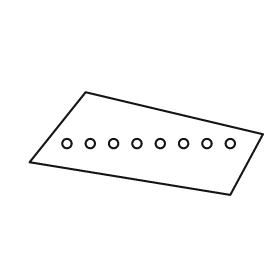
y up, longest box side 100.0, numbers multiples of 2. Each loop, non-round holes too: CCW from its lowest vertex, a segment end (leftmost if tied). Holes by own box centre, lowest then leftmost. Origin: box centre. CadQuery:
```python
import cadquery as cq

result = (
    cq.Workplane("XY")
    .moveTo(36.0, -22.0)
    .lineTo(50.0, 4.0)
    .lineTo(-26.0, 22.0)
    .lineTo(-50.0, -8.0)
    .close()
    .moveTo(-34.0, 0.0)
    .circle(2.0)
    .moveTo(-24.0, 0.0)
    .circle(2.0)
    .moveTo(-14.0, 0.0)
    .circle(2.0)
    .moveTo(-4.0, 0.0)
    .circle(2.0)
    .moveTo(6.0, 0.0)
    .circle(2.0)
    .moveTo(16.0, 0.0)
    .circle(2.0)
    .moveTo(26.0, 0.0)
    .circle(2.0)
    .moveTo(36.0, 0.0)
    .circle(2.0)
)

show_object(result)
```